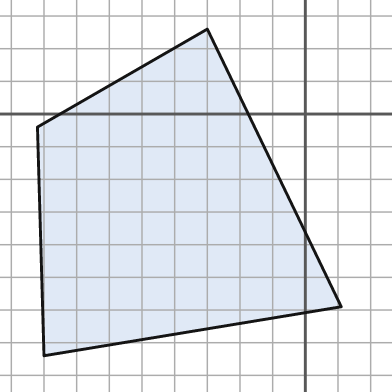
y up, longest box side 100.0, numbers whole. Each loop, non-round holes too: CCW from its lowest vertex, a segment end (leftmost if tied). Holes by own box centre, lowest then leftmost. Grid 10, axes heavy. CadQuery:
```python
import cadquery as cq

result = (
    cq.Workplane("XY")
    .moveTo(-80.0, -74.0)
    .lineTo(11.0, -59.0)
    .lineTo(-30.0, 26.0)
    .lineTo(-82.0, -4.0)
    .close()
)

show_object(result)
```